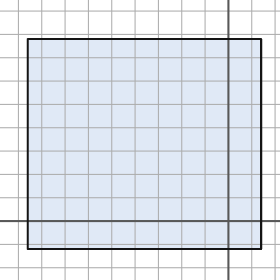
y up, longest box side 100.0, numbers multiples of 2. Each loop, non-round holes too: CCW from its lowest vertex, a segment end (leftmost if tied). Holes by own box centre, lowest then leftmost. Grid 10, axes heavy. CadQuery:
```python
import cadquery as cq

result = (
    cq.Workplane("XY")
    .moveTo(-86.0, -12.0)
    .lineTo(14.0, -12.0)
    .lineTo(14.0, 78.0)
    .lineTo(-86.0, 78.0)
    .close()
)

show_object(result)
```